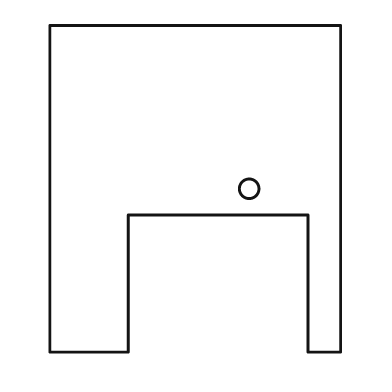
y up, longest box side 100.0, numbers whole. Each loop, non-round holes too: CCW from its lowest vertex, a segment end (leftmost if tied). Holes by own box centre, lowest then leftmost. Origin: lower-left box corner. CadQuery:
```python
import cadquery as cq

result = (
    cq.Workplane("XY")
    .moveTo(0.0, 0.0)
    .lineTo(24.0, 0.0)
    .lineTo(24.0, 42.0)
    .lineTo(79.0, 42.0)
    .lineTo(79.0, 0.0)
    .lineTo(89.0, 0.0)
    .lineTo(89.0, 100.0)
    .lineTo(0.0, 100.0)
    .close()
    .moveTo(61.0, 50.0)
    .circle(3.0)
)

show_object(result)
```